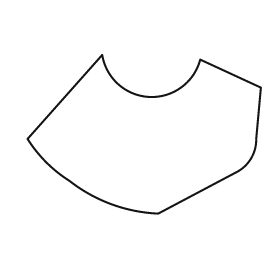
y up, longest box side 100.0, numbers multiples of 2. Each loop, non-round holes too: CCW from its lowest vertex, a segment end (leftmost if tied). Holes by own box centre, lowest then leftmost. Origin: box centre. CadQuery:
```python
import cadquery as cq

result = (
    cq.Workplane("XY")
    .moveTo(6.0, -34.0)
    .lineTo(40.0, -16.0)
    .threePointArc((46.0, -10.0), (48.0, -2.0))
    .lineTo(50.0, 20.0)
    .lineTo(24.0, 32.0)
    .threePointArc((2.0, 16.0), (-18.0, 34.0))
    .lineTo(-50.0, -2.0)
    .threePointArc((-42.0, -12.0), (-32.0, -20.0))
    .threePointArc((-14.0, -30.0), (6.0, -34.0))
    .close()
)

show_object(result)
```